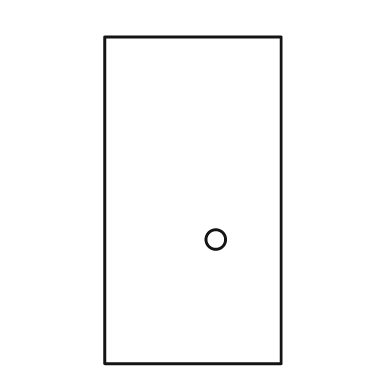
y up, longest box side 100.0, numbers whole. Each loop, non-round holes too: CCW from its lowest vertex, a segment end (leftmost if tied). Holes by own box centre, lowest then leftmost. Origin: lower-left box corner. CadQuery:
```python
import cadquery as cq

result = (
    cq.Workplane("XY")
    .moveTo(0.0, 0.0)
    .lineTo(54.0, 0.0)
    .lineTo(54.0, 100.0)
    .lineTo(0.0, 100.0)
    .close()
    .moveTo(34.0, 38.0)
    .circle(3.0)
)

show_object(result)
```